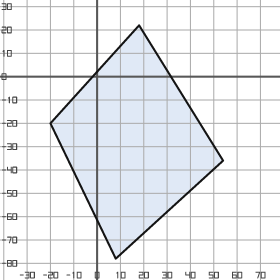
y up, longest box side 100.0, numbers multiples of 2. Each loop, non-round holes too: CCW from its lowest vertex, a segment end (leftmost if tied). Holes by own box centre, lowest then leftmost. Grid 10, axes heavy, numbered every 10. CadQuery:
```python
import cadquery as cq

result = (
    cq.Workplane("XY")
    .moveTo(8.0, -78.0)
    .lineTo(54.0, -36.0)
    .lineTo(18.0, 22.0)
    .lineTo(-20.0, -20.0)
    .close()
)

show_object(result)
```